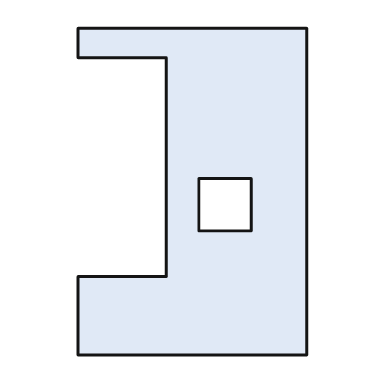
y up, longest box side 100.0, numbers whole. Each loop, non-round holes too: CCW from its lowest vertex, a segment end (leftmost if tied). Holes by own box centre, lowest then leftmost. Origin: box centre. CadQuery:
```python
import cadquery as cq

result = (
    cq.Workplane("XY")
    .moveTo(-35.0, -50.0)
    .lineTo(35.0, -50.0)
    .lineTo(35.0, 50.0)
    .lineTo(-35.0, 50.0)
    .lineTo(-35.0, 41.0)
    .lineTo(-8.0, 41.0)
    .lineTo(-8.0, -26.0)
    .lineTo(-35.0, -26.0)
    .close()
    .moveTo(2.0, -12.0)
    .lineTo(18.0, -12.0)
    .lineTo(18.0, 4.0)
    .lineTo(2.0, 4.0)
    .close()
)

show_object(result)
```